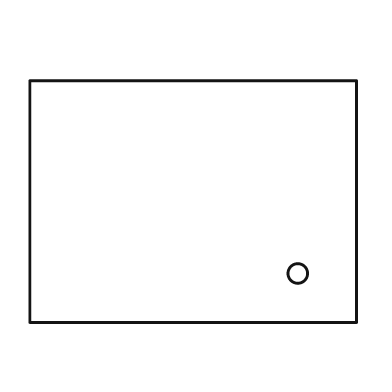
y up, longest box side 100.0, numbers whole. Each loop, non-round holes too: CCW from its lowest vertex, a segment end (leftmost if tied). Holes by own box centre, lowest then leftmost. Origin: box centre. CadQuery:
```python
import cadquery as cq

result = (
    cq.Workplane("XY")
    .moveTo(-50.0, -37.0)
    .lineTo(50.0, -37.0)
    .lineTo(50.0, 37.0)
    .lineTo(-50.0, 37.0)
    .close()
    .moveTo(32.0, -22.0)
    .circle(3.0)
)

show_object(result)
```